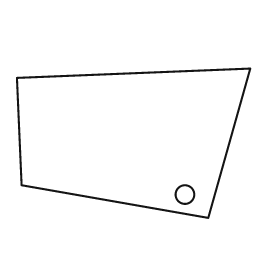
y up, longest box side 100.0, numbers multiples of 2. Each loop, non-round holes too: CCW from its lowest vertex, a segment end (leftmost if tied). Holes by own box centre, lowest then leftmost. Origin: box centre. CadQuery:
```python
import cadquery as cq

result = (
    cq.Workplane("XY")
    .moveTo(32.0, -32.0)
    .lineTo(50.0, 32.0)
    .lineTo(-50.0, 28.0)
    .lineTo(-48.0, -18.0)
    .close()
    .moveTo(22.0, -22.0)
    .circle(4.0)
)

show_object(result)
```